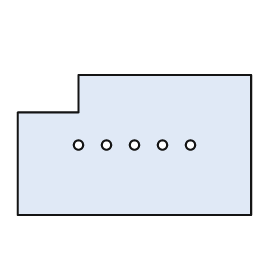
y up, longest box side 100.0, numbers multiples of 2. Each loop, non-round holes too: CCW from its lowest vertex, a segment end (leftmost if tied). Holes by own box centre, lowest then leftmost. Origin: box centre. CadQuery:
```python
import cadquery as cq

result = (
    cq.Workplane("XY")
    .moveTo(-50.0, -30.0)
    .lineTo(50.0, -30.0)
    .lineTo(50.0, 30.0)
    .lineTo(-24.0, 30.0)
    .lineTo(-24.0, 14.0)
    .lineTo(-50.0, 14.0)
    .close()
    .moveTo(-24.0, 0.0)
    .circle(2.0)
    .moveTo(-12.0, 0.0)
    .circle(2.0)
    .moveTo(0.0, 0.0)
    .circle(2.0)
    .moveTo(12.0, 0.0)
    .circle(2.0)
    .moveTo(24.0, 0.0)
    .circle(2.0)
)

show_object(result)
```